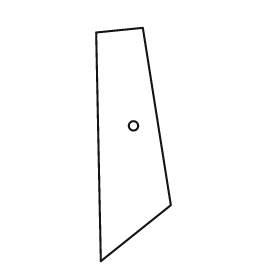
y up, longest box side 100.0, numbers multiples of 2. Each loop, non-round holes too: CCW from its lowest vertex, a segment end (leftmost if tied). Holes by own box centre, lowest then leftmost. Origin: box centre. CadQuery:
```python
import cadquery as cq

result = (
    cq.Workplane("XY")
    .moveTo(-14.0, -50.0)
    .lineTo(16.0, -26.0)
    .lineTo(4.0, 50.0)
    .lineTo(-16.0, 48.0)
    .close()
    .moveTo(0.0, 8.0)
    .circle(2.0)
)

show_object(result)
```